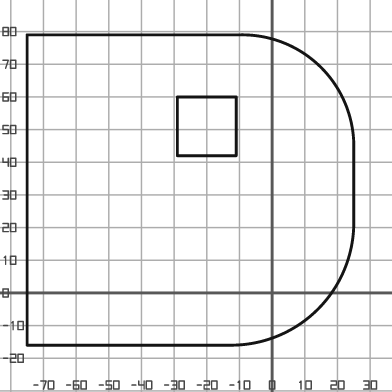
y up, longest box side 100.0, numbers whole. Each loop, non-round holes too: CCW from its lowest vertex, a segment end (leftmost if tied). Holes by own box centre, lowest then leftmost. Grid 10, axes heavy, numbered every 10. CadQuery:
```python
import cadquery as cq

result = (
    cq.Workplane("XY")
    .moveTo(-75.0, -16.0)
    .lineTo(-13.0, -16.0)
    .threePointArc((14.0, -5.0), (25.0, 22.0))
    .lineTo(25.0, 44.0)
    .threePointArc((15.0, 69.0), (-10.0, 79.0))
    .lineTo(-75.0, 79.0)
    .close()
    .moveTo(-29.0, 42.0)
    .lineTo(-11.0, 42.0)
    .lineTo(-11.0, 60.0)
    .lineTo(-29.0, 60.0)
    .close()
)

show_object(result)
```